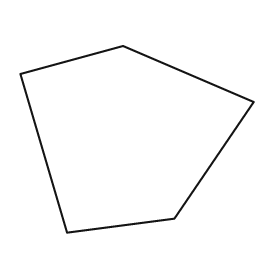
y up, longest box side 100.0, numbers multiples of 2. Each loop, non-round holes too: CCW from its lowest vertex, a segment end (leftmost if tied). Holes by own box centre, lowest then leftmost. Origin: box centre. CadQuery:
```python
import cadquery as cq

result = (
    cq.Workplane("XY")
    .moveTo(-30.0, -40.0)
    .lineTo(16.0, -34.0)
    .lineTo(50.0, 16.0)
    .lineTo(-6.0, 40.0)
    .lineTo(-50.0, 28.0)
    .close()
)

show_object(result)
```